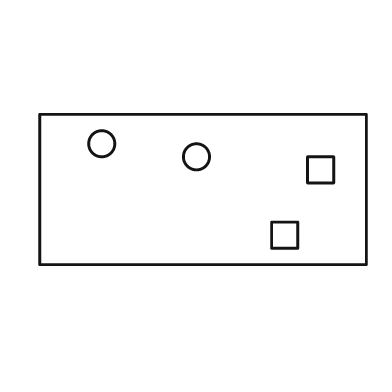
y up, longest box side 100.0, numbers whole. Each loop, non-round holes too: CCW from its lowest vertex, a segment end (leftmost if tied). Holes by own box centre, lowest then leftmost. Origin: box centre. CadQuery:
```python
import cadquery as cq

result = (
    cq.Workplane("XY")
    .moveTo(-50.0, -23.0)
    .lineTo(50.0, -23.0)
    .lineTo(50.0, 23.0)
    .lineTo(-50.0, 23.0)
    .close()
    .moveTo(21.0, -18.0)
    .lineTo(29.0, -18.0)
    .lineTo(29.0, -10.0)
    .lineTo(21.0, -10.0)
    .close()
    .moveTo(32.0, 2.0)
    .lineTo(40.0, 2.0)
    .lineTo(40.0, 10.0)
    .lineTo(32.0, 10.0)
    .close()
    .moveTo(-2.0, 10.0)
    .circle(4.0)
    .moveTo(-31.0, 14.0)
    .circle(4.0)
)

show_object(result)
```